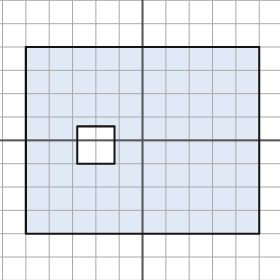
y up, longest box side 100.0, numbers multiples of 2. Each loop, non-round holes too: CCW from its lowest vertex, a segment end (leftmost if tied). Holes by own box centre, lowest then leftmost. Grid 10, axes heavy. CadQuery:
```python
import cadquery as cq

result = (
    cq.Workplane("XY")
    .moveTo(-50.0, -40.0)
    .lineTo(50.0, -40.0)
    .lineTo(50.0, 40.0)
    .lineTo(-50.0, 40.0)
    .close()
    .moveTo(-28.0, -10.0)
    .lineTo(-12.0, -10.0)
    .lineTo(-12.0, 6.0)
    .lineTo(-28.0, 6.0)
    .close()
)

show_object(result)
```